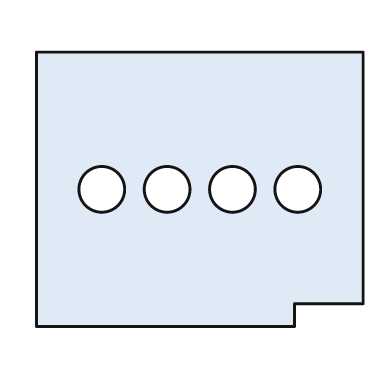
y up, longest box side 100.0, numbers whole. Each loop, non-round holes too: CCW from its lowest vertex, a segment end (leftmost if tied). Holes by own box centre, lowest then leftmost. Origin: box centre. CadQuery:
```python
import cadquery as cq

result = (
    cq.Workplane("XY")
    .moveTo(-50.0, -42.0)
    .lineTo(29.0, -42.0)
    .lineTo(29.0, -35.0)
    .lineTo(50.0, -35.0)
    .lineTo(50.0, 42.0)
    .lineTo(-50.0, 42.0)
    .close()
    .moveTo(-30.0, 0.0)
    .circle(7.0)
    .moveTo(-10.0, 0.0)
    .circle(7.0)
    .moveTo(10.0, 0.0)
    .circle(7.0)
    .moveTo(30.0, 0.0)
    .circle(7.0)
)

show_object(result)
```